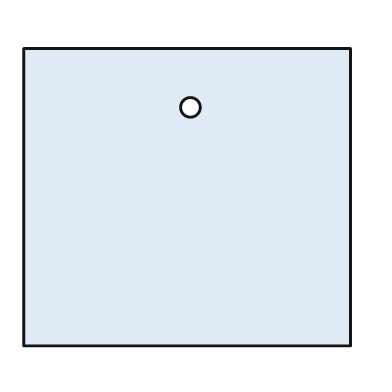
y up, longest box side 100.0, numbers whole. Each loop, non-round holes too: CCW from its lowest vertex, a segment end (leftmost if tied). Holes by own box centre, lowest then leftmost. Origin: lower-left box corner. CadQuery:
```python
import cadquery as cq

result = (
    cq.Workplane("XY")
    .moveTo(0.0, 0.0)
    .lineTo(100.0, 0.0)
    .lineTo(100.0, 91.0)
    .lineTo(0.0, 91.0)
    .close()
    .moveTo(51.0, 73.0)
    .circle(3.0)
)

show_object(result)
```